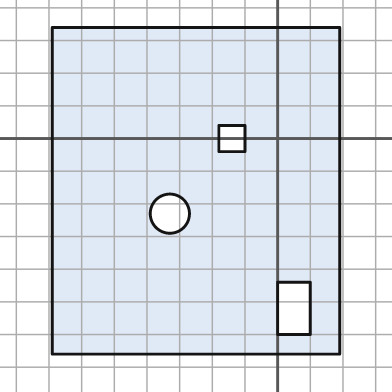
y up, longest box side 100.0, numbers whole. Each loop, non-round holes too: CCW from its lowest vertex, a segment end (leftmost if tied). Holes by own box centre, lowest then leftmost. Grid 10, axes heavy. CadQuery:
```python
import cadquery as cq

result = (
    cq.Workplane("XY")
    .moveTo(-69.0, -66.0)
    .lineTo(19.0, -66.0)
    .lineTo(19.0, 34.0)
    .lineTo(-69.0, 34.0)
    .close()
    .moveTo(0.0, -60.0)
    .lineTo(10.0, -60.0)
    .lineTo(10.0, -44.0)
    .lineTo(0.0, -44.0)
    .close()
    .moveTo(-33.0, -23.0)
    .circle(6.0)
    .moveTo(-18.0, -4.0)
    .lineTo(-10.0, -4.0)
    .lineTo(-10.0, 4.0)
    .lineTo(-18.0, 4.0)
    .close()
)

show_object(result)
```